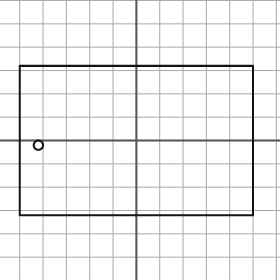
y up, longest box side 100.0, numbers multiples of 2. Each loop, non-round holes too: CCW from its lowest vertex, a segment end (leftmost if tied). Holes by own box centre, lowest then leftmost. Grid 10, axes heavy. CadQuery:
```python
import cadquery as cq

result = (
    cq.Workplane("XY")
    .moveTo(-50.0, -32.0)
    .lineTo(50.0, -32.0)
    .lineTo(50.0, 32.0)
    .lineTo(-50.0, 32.0)
    .close()
    .moveTo(-42.0, -2.0)
    .circle(2.0)
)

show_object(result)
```